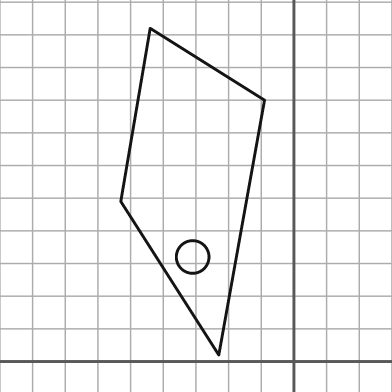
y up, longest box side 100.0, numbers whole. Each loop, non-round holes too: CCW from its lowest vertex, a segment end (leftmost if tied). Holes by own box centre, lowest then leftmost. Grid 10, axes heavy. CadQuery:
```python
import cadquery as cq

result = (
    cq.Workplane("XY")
    .moveTo(-23.0, 2.0)
    .lineTo(-9.0, 80.0)
    .lineTo(-44.0, 102.0)
    .lineTo(-53.0, 49.0)
    .close()
    .moveTo(-31.0, 32.0)
    .circle(5.0)
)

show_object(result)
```